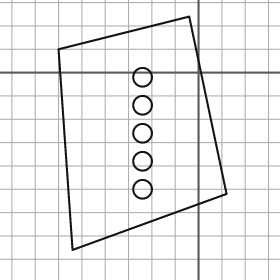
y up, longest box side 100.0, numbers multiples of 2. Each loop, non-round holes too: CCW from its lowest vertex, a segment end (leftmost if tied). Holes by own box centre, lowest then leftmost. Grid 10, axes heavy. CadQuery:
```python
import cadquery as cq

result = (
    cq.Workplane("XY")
    .moveTo(-54.0, -76.0)
    .lineTo(12.0, -52.0)
    .lineTo(-4.0, 24.0)
    .lineTo(-60.0, 10.0)
    .close()
    .moveTo(-24.0, -50.0)
    .circle(4.0)
    .moveTo(-24.0, -38.0)
    .circle(4.0)
    .moveTo(-24.0, -26.0)
    .circle(4.0)
    .moveTo(-24.0, -14.0)
    .circle(4.0)
    .moveTo(-24.0, -2.0)
    .circle(4.0)
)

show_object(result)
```